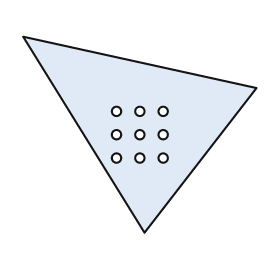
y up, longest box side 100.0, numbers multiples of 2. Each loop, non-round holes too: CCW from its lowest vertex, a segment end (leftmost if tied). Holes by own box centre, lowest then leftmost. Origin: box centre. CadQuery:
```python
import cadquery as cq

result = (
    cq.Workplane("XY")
    .moveTo(2.0, -42.0)
    .lineTo(50.0, 20.0)
    .lineTo(-50.0, 42.0)
    .close()
    .moveTo(-10.0, -10.0)
    .circle(2.0)
    .moveTo(0.0, -10.0)
    .circle(2.0)
    .moveTo(10.0, -10.0)
    .circle(2.0)
    .moveTo(-10.0, 0.0)
    .circle(2.0)
    .moveTo(0.0, 0.0)
    .circle(2.0)
    .moveTo(10.0, 0.0)
    .circle(2.0)
    .moveTo(-10.0, 10.0)
    .circle(2.0)
    .moveTo(0.0, 10.0)
    .circle(2.0)
    .moveTo(10.0, 10.0)
    .circle(2.0)
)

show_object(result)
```